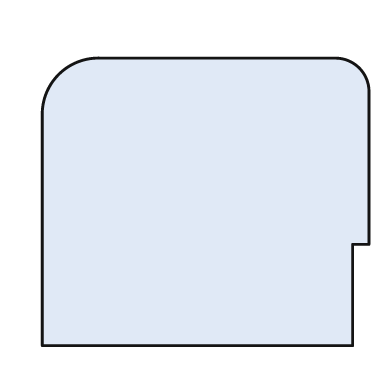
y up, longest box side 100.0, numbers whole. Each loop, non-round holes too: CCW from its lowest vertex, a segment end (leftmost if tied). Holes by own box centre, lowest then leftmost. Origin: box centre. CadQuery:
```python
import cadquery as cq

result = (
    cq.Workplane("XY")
    .moveTo(-50.0, -44.0)
    .lineTo(45.0, -44.0)
    .lineTo(45.0, -13.0)
    .lineTo(50.0, -13.0)
    .lineTo(50.0, 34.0)
    .threePointArc((47.0, 41.0), (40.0, 44.0))
    .lineTo(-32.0, 44.0)
    .threePointArc((-45.0, 39.0), (-50.0, 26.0))
    .close()
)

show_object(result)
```